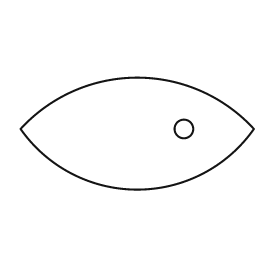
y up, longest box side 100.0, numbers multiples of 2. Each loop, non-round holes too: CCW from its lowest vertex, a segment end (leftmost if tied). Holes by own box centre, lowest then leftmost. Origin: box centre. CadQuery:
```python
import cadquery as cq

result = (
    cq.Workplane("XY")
    .moveTo(-50.0, 2.0)
    .threePointArc((0.0, -24.0), (50.0, 2.0))
    .threePointArc((0.0, 24.0), (-50.0, 2.0))
    .close()
    .moveTo(20.0, 2.0)
    .circle(4.0)
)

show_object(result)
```